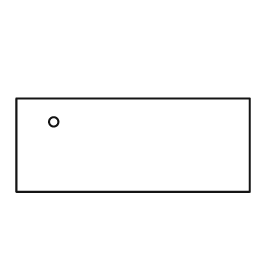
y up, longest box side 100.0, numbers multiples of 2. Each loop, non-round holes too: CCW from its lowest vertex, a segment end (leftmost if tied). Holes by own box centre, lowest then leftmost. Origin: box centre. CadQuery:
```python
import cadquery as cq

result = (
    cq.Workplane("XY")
    .moveTo(-50.0, -20.0)
    .lineTo(50.0, -20.0)
    .lineTo(50.0, 20.0)
    .lineTo(-50.0, 20.0)
    .close()
    .moveTo(-34.0, 10.0)
    .circle(2.0)
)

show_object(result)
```